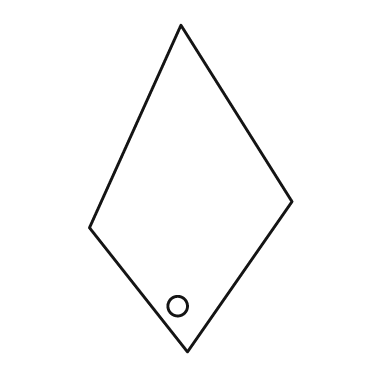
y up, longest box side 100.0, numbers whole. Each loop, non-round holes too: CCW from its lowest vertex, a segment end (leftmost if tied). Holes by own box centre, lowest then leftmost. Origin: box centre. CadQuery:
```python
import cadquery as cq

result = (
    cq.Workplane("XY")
    .moveTo(-1.0, -50.0)
    .lineTo(31.0, -4.0)
    .lineTo(-3.0, 50.0)
    .lineTo(-31.0, -12.0)
    .close()
    .moveTo(-4.0, -36.0)
    .circle(3.0)
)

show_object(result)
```